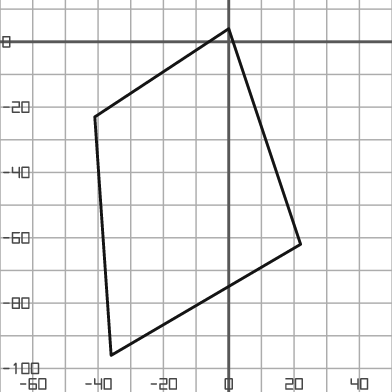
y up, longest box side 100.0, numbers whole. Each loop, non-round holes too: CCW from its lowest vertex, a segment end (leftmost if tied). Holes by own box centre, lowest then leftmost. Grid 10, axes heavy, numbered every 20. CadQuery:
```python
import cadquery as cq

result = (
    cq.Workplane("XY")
    .moveTo(-36.0, -96.0)
    .lineTo(22.0, -62.0)
    .lineTo(0.0, 4.0)
    .lineTo(-41.0, -23.0)
    .close()
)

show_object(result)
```